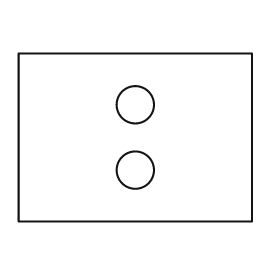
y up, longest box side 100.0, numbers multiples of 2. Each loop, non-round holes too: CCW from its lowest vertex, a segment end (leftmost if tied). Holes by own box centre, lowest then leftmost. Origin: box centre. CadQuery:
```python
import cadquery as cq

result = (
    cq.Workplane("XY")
    .moveTo(-50.0, -36.0)
    .lineTo(50.0, -36.0)
    .lineTo(50.0, 36.0)
    .lineTo(-50.0, 36.0)
    .close()
    .moveTo(0.0, -14.0)
    .circle(8.0)
    .moveTo(0.0, 14.0)
    .circle(8.0)
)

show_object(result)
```